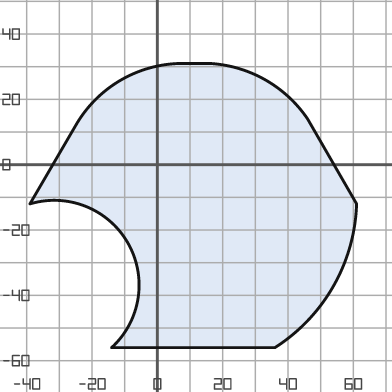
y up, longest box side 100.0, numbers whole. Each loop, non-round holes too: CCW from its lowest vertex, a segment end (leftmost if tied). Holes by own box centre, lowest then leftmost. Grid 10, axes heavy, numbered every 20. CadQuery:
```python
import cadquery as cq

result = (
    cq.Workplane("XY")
    .moveTo(-14.0, -56.0)
    .lineTo(36.0, -56.0)
    .threePointArc((54.0, -37.0), (61.0, -12.0))
    .lineTo(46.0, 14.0)
    .threePointArc((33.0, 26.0), (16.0, 31.0))
    .lineTo(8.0, 31.0)
    .threePointArc((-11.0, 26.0), (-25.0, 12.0))
    .lineTo(-39.0, -12.0)
    .threePointArc((-9.0, -24.0), (-14.0, -56.0))
    .close()
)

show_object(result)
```